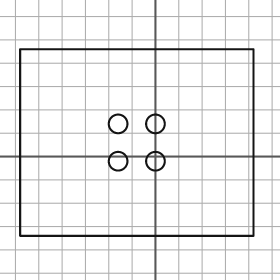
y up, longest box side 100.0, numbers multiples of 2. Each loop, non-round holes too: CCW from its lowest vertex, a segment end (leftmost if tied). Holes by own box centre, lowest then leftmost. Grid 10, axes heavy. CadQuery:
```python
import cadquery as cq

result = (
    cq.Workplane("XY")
    .moveTo(-58.0, -34.0)
    .lineTo(42.0, -34.0)
    .lineTo(42.0, 46.0)
    .lineTo(-58.0, 46.0)
    .close()
    .moveTo(-16.0, -2.0)
    .circle(4.0)
    .moveTo(0.0, -2.0)
    .circle(4.0)
    .moveTo(-16.0, 14.0)
    .circle(4.0)
    .moveTo(0.0, 14.0)
    .circle(4.0)
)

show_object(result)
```